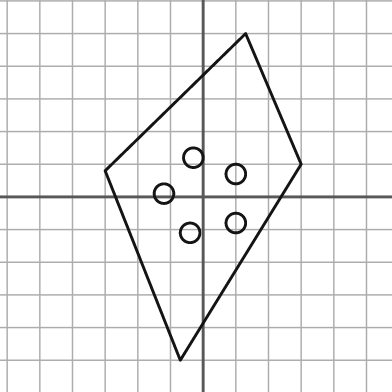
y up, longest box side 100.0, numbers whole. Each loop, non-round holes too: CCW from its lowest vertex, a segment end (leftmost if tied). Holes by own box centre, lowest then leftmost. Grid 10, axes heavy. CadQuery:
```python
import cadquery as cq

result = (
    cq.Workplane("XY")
    .moveTo(-7.0, -50.0)
    .lineTo(30.0, 10.0)
    .lineTo(13.0, 50.0)
    .lineTo(-30.0, 8.0)
    .close()
    .moveTo(-4.0, -11.0)
    .circle(3.0)
    .moveTo(10.0, -8.0)
    .circle(3.0)
    .moveTo(-12.0, 1.0)
    .circle(3.0)
    .moveTo(10.0, 7.0)
    .circle(3.0)
    .moveTo(-3.0, 12.0)
    .circle(3.0)
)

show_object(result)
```